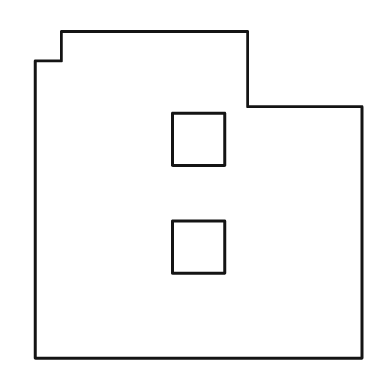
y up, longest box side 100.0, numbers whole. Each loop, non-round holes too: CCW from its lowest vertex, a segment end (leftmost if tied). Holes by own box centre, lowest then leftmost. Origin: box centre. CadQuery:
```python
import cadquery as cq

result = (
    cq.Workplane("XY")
    .moveTo(-50.0, -50.0)
    .lineTo(50.0, -50.0)
    .lineTo(50.0, 27.0)
    .lineTo(15.0, 27.0)
    .lineTo(15.0, 50.0)
    .lineTo(-42.0, 50.0)
    .lineTo(-42.0, 41.0)
    .lineTo(-50.0, 41.0)
    .close()
    .moveTo(-8.0, -24.0)
    .lineTo(8.0, -24.0)
    .lineTo(8.0, -8.0)
    .lineTo(-8.0, -8.0)
    .close()
    .moveTo(-8.0, 9.0)
    .lineTo(8.0, 9.0)
    .lineTo(8.0, 25.0)
    .lineTo(-8.0, 25.0)
    .close()
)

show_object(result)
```